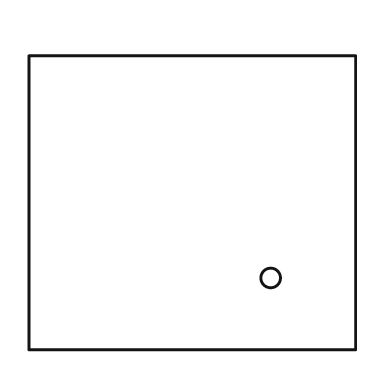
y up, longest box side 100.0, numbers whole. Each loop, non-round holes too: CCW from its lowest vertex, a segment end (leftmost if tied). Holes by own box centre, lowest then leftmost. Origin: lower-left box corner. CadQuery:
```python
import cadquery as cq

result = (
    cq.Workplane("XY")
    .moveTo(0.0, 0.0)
    .lineTo(100.0, 0.0)
    .lineTo(100.0, 90.0)
    .lineTo(0.0, 90.0)
    .close()
    .moveTo(74.0, 22.0)
    .circle(3.0)
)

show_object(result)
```